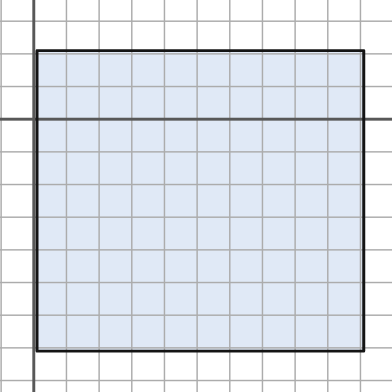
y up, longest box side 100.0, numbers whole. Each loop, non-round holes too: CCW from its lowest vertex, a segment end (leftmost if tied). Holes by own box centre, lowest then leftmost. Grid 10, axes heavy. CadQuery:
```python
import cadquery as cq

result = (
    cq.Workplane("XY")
    .moveTo(1.0, -71.0)
    .lineTo(101.0, -71.0)
    .lineTo(101.0, 21.0)
    .lineTo(1.0, 21.0)
    .close()
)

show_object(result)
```